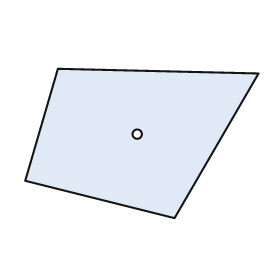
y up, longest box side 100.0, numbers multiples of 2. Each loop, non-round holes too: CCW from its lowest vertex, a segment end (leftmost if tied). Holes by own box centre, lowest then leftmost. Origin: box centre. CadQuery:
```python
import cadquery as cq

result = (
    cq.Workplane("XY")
    .moveTo(14.0, -32.0)
    .lineTo(50.0, 30.0)
    .lineTo(-36.0, 32.0)
    .lineTo(-50.0, -16.0)
    .close()
    .moveTo(-2.0, 4.0)
    .circle(2.0)
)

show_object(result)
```